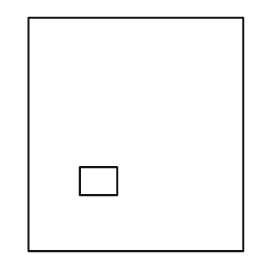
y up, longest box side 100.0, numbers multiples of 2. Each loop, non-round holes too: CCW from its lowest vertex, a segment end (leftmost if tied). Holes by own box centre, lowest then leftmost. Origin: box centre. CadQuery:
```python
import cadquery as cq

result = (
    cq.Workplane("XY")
    .moveTo(-46.0, -50.0)
    .lineTo(46.0, -50.0)
    .lineTo(46.0, 50.0)
    .lineTo(-46.0, 50.0)
    .close()
    .moveTo(-24.0, -26.0)
    .lineTo(-8.0, -26.0)
    .lineTo(-8.0, -14.0)
    .lineTo(-24.0, -14.0)
    .close()
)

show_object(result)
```